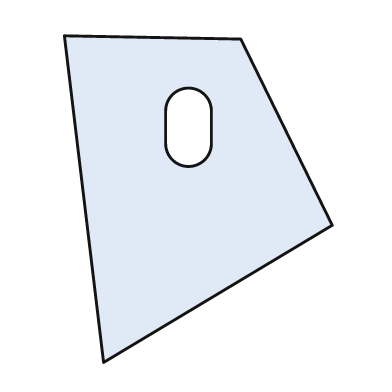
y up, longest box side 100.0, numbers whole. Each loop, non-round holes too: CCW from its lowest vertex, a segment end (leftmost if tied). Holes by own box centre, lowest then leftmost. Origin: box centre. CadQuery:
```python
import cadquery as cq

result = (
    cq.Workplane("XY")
    .moveTo(-29.0, -50.0)
    .lineTo(41.0, -8.0)
    .lineTo(13.0, 49.0)
    .lineTo(-41.0, 50.0)
    .close()
    .moveTo(-10.0, 17.0)
    .threePointArc((-3.0, 10.0), (4.0, 17.0))
    .lineTo(4.0, 27.0)
    .threePointArc((-3.0, 34.0), (-10.0, 27.0))
    .close()
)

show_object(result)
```